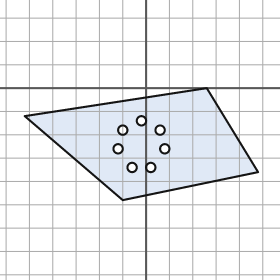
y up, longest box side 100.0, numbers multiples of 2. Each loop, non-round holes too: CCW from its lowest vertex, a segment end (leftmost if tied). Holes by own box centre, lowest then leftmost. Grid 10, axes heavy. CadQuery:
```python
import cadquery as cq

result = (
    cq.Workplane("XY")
    .moveTo(-10.0, -48.0)
    .lineTo(48.0, -36.0)
    .lineTo(26.0, 0.0)
    .lineTo(-52.0, -12.0)
    .close()
    .moveTo(-6.0, -34.0)
    .circle(2.0)
    .moveTo(2.0, -34.0)
    .circle(2.0)
    .moveTo(-12.0, -26.0)
    .circle(2.0)
    .moveTo(8.0, -26.0)
    .circle(2.0)
    .moveTo(-10.0, -18.0)
    .circle(2.0)
    .moveTo(6.0, -18.0)
    .circle(2.0)
    .moveTo(-2.0, -14.0)
    .circle(2.0)
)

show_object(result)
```